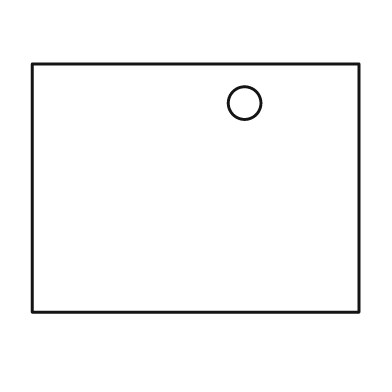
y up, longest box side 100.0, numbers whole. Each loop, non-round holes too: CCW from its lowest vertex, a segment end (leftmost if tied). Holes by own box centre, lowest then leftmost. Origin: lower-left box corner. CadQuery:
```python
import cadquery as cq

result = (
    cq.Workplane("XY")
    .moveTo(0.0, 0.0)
    .lineTo(100.0, 0.0)
    .lineTo(100.0, 76.0)
    .lineTo(0.0, 76.0)
    .close()
    .moveTo(65.0, 64.0)
    .circle(5.0)
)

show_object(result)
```